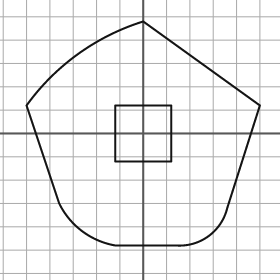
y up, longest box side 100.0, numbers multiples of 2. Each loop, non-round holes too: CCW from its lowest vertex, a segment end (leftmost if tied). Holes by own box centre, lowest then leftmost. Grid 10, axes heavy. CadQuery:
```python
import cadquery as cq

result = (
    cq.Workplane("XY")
    .moveTo(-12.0, -48.0)
    .lineTo(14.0, -48.0)
    .threePointArc((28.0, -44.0), (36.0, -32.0))
    .lineTo(50.0, 12.0)
    .lineTo(0.0, 48.0)
    .threePointArc((-28.0, 34.0), (-50.0, 12.0))
    .lineTo(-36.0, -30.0)
    .threePointArc((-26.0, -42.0), (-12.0, -48.0))
    .close()
    .moveTo(-12.0, -12.0)
    .lineTo(12.0, -12.0)
    .lineTo(12.0, 12.0)
    .lineTo(-12.0, 12.0)
    .close()
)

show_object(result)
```